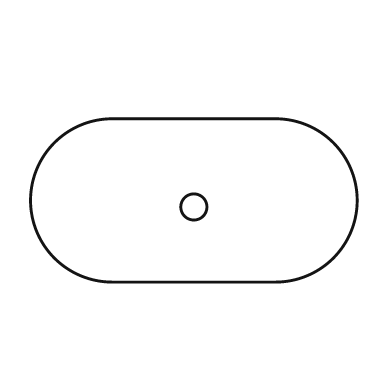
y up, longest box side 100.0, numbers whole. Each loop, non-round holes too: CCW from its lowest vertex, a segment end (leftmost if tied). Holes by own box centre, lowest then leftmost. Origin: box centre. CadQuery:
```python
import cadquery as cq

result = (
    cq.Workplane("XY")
    .moveTo(-25.0, -25.0)
    .lineTo(25.0, -25.0)
    .threePointArc((50.0, 0.0), (25.0, 25.0))
    .lineTo(-25.0, 25.0)
    .threePointArc((-50.0, 0.0), (-25.0, -25.0))
    .close()
    .moveTo(0.0, -2.0)
    .circle(4.0)
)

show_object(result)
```